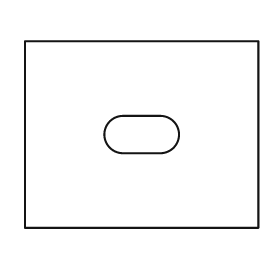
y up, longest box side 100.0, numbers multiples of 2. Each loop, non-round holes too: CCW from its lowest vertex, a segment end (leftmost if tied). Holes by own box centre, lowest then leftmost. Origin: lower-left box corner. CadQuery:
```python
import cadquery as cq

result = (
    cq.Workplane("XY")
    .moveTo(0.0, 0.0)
    .lineTo(100.0, 0.0)
    .lineTo(100.0, 80.0)
    .lineTo(0.0, 80.0)
    .close()
    .moveTo(42.0, 32.0)
    .lineTo(58.0, 32.0)
    .threePointArc((66.0, 40.0), (58.0, 48.0))
    .lineTo(42.0, 48.0)
    .threePointArc((34.0, 40.0), (42.0, 32.0))
    .close()
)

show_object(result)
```